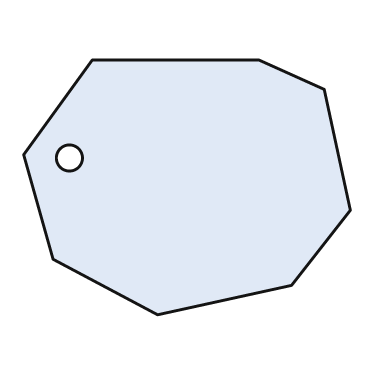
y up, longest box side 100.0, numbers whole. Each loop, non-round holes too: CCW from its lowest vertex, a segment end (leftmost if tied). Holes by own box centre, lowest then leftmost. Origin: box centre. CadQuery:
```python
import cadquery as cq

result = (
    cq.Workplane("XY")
    .moveTo(-9.0, -39.0)
    .lineTo(32.0, -30.0)
    .lineTo(50.0, -7.0)
    .lineTo(42.0, 30.0)
    .lineTo(22.0, 39.0)
    .lineTo(-29.0, 39.0)
    .lineTo(-50.0, 10.0)
    .lineTo(-41.0, -22.0)
    .close()
    .moveTo(-36.0, 9.0)
    .circle(4.0)
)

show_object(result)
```